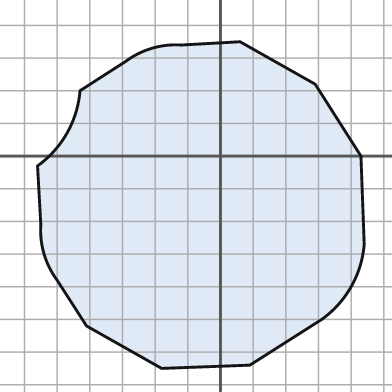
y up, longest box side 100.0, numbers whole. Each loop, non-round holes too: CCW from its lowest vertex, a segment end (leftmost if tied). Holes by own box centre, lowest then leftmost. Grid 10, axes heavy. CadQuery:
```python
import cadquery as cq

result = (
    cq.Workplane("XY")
    .moveTo(-18.0, -65.0)
    .lineTo(9.0, -64.0)
    .lineTo(31.0, -50.0)
    .threePointArc((40.0, -40.0), (44.0, -27.0))
    .lineTo(43.0, 0.0)
    .lineTo(29.0, 22.0)
    .lineTo(6.0, 35.0)
    .lineTo(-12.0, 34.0)
    .threePointArc((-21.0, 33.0), (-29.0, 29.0))
    .lineTo(-43.0, 20.0)
    .threePointArc((-47.0, 7.0), (-56.0, -3.0))
    .lineTo(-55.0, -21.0)
    .threePointArc((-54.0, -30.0), (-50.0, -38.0))
    .lineTo(-41.0, -52.0)
    .close()
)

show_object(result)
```